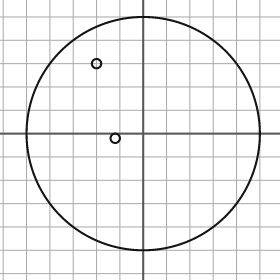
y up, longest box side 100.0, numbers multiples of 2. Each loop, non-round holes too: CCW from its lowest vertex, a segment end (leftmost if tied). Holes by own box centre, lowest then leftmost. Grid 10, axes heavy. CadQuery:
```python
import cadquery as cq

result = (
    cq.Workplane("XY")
    .moveTo(0.0, 0.0)
    .circle(50.0)
    .moveTo(-12.0, -2.0)
    .circle(2.0)
    .moveTo(-20.0, 30.0)
    .circle(2.0)
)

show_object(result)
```